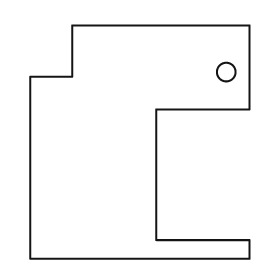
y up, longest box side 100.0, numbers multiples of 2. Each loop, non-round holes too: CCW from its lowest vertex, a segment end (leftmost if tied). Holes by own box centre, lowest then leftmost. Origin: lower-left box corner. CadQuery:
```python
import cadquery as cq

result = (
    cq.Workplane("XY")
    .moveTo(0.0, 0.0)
    .lineTo(94.0, 0.0)
    .lineTo(94.0, 8.0)
    .lineTo(54.0, 8.0)
    .lineTo(54.0, 64.0)
    .lineTo(94.0, 64.0)
    .lineTo(94.0, 100.0)
    .lineTo(18.0, 100.0)
    .lineTo(18.0, 78.0)
    .lineTo(0.0, 78.0)
    .close()
    .moveTo(84.0, 80.0)
    .circle(4.0)
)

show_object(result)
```